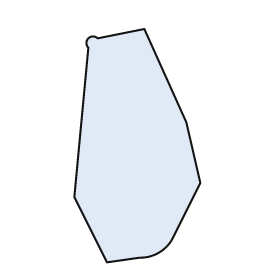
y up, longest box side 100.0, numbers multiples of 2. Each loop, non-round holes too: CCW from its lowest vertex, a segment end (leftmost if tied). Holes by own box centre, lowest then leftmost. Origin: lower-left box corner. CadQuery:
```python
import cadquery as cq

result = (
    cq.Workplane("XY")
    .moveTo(14.0, 0.0)
    .lineTo(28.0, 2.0)
    .threePointArc((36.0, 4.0), (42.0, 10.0))
    .lineTo(54.0, 34.0)
    .lineTo(48.0, 60.0)
    .lineTo(30.0, 100.0)
    .lineTo(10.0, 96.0)
    .threePointArc((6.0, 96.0), (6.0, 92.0))
    .lineTo(0.0, 28.0)
    .close()
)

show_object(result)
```